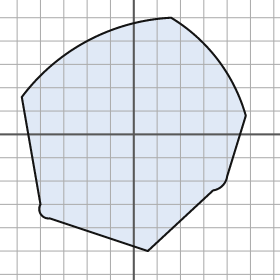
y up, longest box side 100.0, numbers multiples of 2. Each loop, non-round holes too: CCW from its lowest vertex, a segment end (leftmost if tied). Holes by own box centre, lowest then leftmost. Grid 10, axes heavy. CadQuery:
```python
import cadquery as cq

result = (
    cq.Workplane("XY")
    .moveTo(6.0, -50.0)
    .lineTo(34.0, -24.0)
    .threePointArc((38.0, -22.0), (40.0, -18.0))
    .lineTo(48.0, 8.0)
    .threePointArc((36.0, 32.0), (16.0, 50.0))
    .threePointArc((-20.0, 40.0), (-48.0, 16.0))
    .lineTo(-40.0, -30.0)
    .threePointArc((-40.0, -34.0), (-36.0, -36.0))
    .close()
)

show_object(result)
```